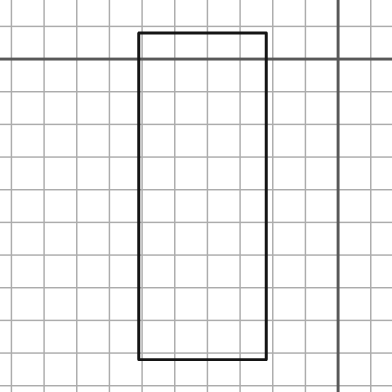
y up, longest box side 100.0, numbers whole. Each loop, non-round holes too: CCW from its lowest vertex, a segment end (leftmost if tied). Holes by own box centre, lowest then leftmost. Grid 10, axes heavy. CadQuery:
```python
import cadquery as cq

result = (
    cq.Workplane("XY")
    .moveTo(-61.0, -92.0)
    .lineTo(-22.0, -92.0)
    .lineTo(-22.0, 8.0)
    .lineTo(-61.0, 8.0)
    .close()
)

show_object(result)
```